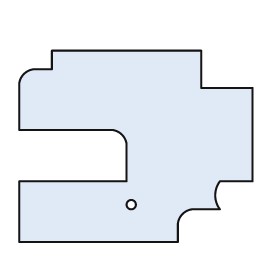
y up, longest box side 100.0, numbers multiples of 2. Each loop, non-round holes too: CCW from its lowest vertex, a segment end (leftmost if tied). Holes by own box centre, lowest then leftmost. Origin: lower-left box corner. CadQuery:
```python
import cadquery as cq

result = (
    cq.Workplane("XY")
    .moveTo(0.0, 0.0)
    .lineTo(68.0, 0.0)
    .lineTo(68.0, 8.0)
    .threePointArc((70.0, 12.0), (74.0, 14.0))
    .lineTo(86.0, 14.0)
    .threePointArc((84.0, 20.0), (86.0, 26.0))
    .lineTo(100.0, 26.0)
    .lineTo(100.0, 66.0)
    .lineTo(78.0, 66.0)
    .lineTo(78.0, 82.0)
    .lineTo(14.0, 82.0)
    .lineTo(14.0, 74.0)
    .lineTo(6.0, 74.0)
    .threePointArc((2.0, 72.0), (0.0, 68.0))
    .lineTo(0.0, 48.0)
    .lineTo(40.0, 48.0)
    .threePointArc((44.0, 46.0), (46.0, 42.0))
    .lineTo(46.0, 26.0)
    .lineTo(0.0, 26.0)
    .close()
    .moveTo(48.0, 16.0)
    .circle(2.0)
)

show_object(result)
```